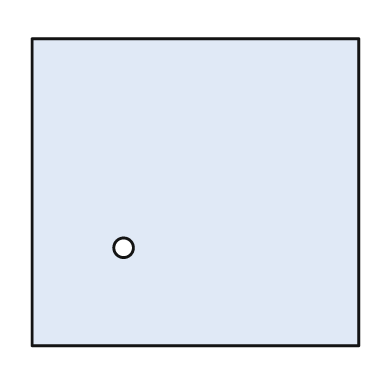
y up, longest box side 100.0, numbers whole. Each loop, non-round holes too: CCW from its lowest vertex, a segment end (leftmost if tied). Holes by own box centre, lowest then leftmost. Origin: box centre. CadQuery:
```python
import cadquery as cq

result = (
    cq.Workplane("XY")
    .moveTo(-50.0, -47.0)
    .lineTo(50.0, -47.0)
    .lineTo(50.0, 47.0)
    .lineTo(-50.0, 47.0)
    .close()
    .moveTo(-22.0, -17.0)
    .circle(3.0)
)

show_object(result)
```